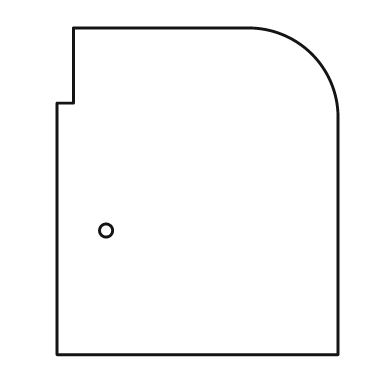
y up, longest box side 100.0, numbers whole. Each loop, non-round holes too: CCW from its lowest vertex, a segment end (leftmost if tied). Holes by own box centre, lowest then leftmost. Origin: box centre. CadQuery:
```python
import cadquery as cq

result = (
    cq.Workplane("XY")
    .moveTo(-43.0, -50.0)
    .lineTo(43.0, -50.0)
    .lineTo(43.0, 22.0)
    .threePointArc((35.0, 42.0), (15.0, 50.0))
    .lineTo(-38.0, 50.0)
    .lineTo(-38.0, 27.0)
    .lineTo(-43.0, 27.0)
    .close()
    .moveTo(-28.0, -12.0)
    .circle(2.0)
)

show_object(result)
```